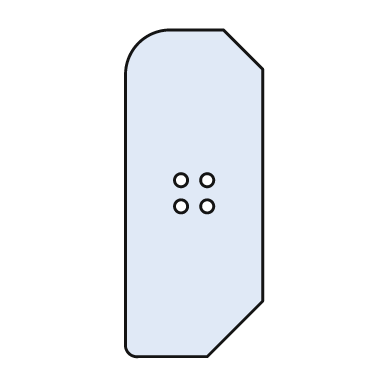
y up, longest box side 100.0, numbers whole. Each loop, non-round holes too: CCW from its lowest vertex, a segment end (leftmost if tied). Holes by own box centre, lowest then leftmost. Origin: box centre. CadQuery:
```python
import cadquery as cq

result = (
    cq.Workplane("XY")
    .moveTo(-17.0, -50.0)
    .lineTo(4.0, -50.0)
    .lineTo(21.0, -33.0)
    .lineTo(21.0, 38.0)
    .lineTo(9.0, 50.0)
    .lineTo(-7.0, 50.0)
    .threePointArc((-17.0, 46.0), (-21.0, 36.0))
    .lineTo(-21.0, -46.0)
    .threePointArc((-20.0, -49.0), (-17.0, -50.0))
    .close()
    .moveTo(-4.0, -4.0)
    .circle(2.0)
    .moveTo(4.0, -4.0)
    .circle(2.0)
    .moveTo(-4.0, 4.0)
    .circle(2.0)
    .moveTo(4.0, 4.0)
    .circle(2.0)
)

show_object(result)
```